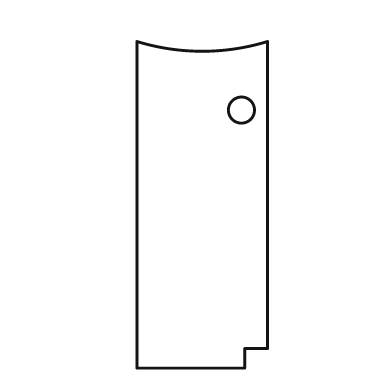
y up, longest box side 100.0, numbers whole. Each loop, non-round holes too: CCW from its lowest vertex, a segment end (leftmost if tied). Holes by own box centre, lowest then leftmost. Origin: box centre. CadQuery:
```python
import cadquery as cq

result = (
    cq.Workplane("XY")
    .moveTo(-20.0, -50.0)
    .lineTo(13.0, -50.0)
    .lineTo(13.0, -44.0)
    .lineTo(20.0, -44.0)
    .lineTo(20.0, 50.0)
    .threePointArc((0.0, 47.0), (-20.0, 50.0))
    .close()
    .moveTo(12.0, 29.0)
    .circle(4.0)
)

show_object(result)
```